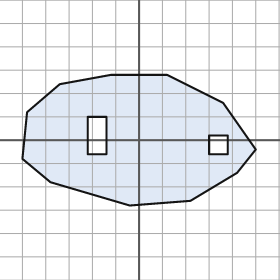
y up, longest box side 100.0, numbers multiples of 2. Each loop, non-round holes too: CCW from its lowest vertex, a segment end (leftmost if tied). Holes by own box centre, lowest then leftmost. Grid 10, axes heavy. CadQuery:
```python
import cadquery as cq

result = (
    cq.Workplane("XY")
    .moveTo(-4.0, -28.0)
    .lineTo(22.0, -26.0)
    .lineTo(42.0, -14.0)
    .lineTo(50.0, -4.0)
    .lineTo(36.0, 16.0)
    .lineTo(12.0, 28.0)
    .lineTo(-12.0, 28.0)
    .lineTo(-34.0, 24.0)
    .lineTo(-48.0, 12.0)
    .lineTo(-50.0, -8.0)
    .lineTo(-38.0, -18.0)
    .close()
    .moveTo(30.0, -6.0)
    .lineTo(38.0, -6.0)
    .lineTo(38.0, 2.0)
    .lineTo(30.0, 2.0)
    .close()
    .moveTo(-22.0, -6.0)
    .lineTo(-14.0, -6.0)
    .lineTo(-14.0, 10.0)
    .lineTo(-22.0, 10.0)
    .close()
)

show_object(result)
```